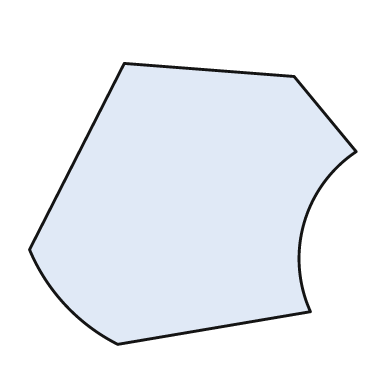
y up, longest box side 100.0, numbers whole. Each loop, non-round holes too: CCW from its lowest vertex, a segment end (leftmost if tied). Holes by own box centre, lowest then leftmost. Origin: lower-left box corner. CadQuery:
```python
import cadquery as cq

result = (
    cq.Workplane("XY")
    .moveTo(27.0, 0.0)
    .lineTo(86.0, 10.0)
    .threePointArc((84.0, 37.0), (100.0, 59.0))
    .lineTo(81.0, 82.0)
    .lineTo(29.0, 86.0)
    .lineTo(0.0, 29.0)
    .threePointArc((11.0, 12.0), (27.0, 0.0))
    .close()
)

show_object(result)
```